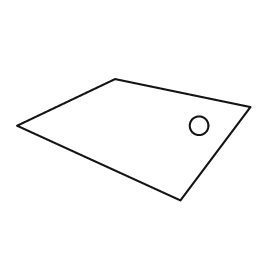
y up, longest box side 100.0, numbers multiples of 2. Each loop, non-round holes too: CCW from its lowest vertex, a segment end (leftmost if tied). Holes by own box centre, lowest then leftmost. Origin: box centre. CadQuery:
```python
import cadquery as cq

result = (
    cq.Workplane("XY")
    .moveTo(20.0, -26.0)
    .lineTo(50.0, 14.0)
    .lineTo(-8.0, 26.0)
    .lineTo(-50.0, 6.0)
    .close()
    .moveTo(28.0, 6.0)
    .circle(4.0)
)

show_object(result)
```